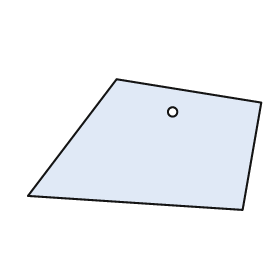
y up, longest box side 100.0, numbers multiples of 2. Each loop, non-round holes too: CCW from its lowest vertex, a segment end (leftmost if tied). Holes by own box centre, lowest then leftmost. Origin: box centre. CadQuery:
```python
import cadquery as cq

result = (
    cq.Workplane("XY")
    .moveTo(42.0, -28.0)
    .lineTo(50.0, 18.0)
    .lineTo(-12.0, 28.0)
    .lineTo(-50.0, -22.0)
    .close()
    .moveTo(12.0, 14.0)
    .circle(2.0)
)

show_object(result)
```